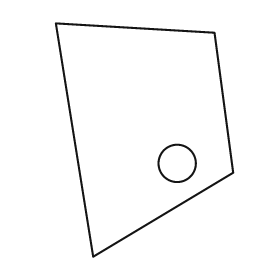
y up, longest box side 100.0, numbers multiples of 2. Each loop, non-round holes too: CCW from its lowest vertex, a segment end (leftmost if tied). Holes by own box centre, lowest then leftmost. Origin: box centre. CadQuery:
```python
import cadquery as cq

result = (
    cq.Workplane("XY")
    .moveTo(-22.0, -50.0)
    .lineTo(38.0, -14.0)
    .lineTo(30.0, 46.0)
    .lineTo(-38.0, 50.0)
    .close()
    .moveTo(14.0, -10.0)
    .circle(8.0)
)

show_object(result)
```